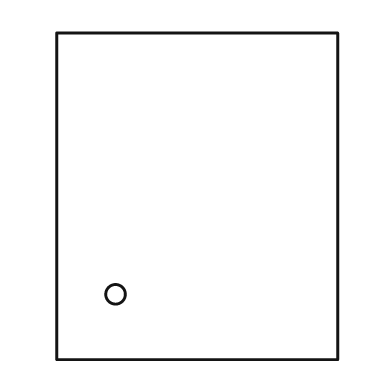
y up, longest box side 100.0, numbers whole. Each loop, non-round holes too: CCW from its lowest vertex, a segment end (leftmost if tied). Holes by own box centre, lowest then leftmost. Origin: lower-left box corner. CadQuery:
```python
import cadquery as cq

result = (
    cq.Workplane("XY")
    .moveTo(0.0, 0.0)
    .lineTo(86.0, 0.0)
    .lineTo(86.0, 100.0)
    .lineTo(0.0, 100.0)
    .close()
    .moveTo(18.0, 20.0)
    .circle(3.0)
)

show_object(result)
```